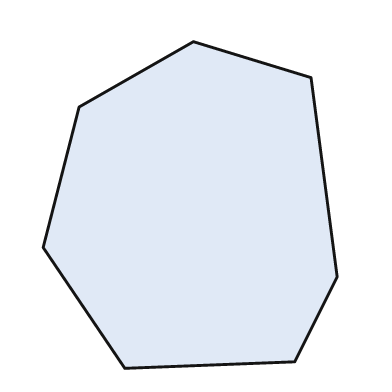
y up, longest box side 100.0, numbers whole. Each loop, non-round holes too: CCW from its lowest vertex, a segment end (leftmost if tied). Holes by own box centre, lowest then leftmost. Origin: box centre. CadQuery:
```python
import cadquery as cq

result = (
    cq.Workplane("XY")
    .moveTo(-20.0, -50.0)
    .lineTo(32.0, -48.0)
    .lineTo(45.0, -22.0)
    .lineTo(37.0, 39.0)
    .lineTo(1.0, 50.0)
    .lineTo(-34.0, 30.0)
    .lineTo(-45.0, -13.0)
    .close()
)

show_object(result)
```